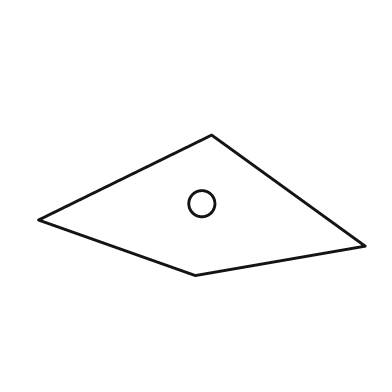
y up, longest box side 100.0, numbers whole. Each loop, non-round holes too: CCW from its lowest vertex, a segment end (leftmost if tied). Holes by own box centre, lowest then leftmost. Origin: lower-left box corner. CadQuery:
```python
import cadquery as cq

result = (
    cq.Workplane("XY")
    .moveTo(48.0, 0.0)
    .lineTo(100.0, 9.0)
    .lineTo(53.0, 43.0)
    .lineTo(0.0, 17.0)
    .close()
    .moveTo(50.0, 22.0)
    .circle(4.0)
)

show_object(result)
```